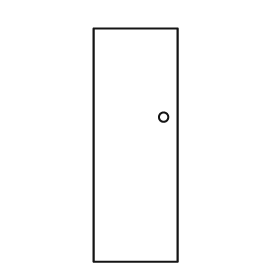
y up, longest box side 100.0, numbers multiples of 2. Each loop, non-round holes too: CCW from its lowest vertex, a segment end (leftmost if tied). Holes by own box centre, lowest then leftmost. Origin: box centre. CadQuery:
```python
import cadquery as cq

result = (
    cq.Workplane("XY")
    .moveTo(-18.0, -50.0)
    .lineTo(18.0, -50.0)
    .lineTo(18.0, 50.0)
    .lineTo(-18.0, 50.0)
    .close()
    .moveTo(12.0, 12.0)
    .circle(2.0)
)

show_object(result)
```